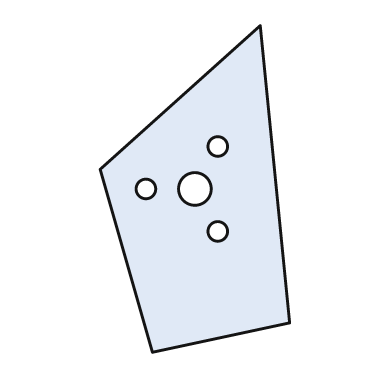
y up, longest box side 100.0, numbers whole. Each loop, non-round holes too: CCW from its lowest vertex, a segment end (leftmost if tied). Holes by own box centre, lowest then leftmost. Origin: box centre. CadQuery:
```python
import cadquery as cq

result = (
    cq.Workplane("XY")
    .moveTo(-13.0, -50.0)
    .lineTo(29.0, -41.0)
    .lineTo(20.0, 50.0)
    .lineTo(-29.0, 6.0)
    .close()
    .moveTo(7.0, -13.0)
    .circle(3.0)
    .moveTo(-15.0, 0.0)
    .circle(3.0)
    .moveTo(0.0, 0.0)
    .circle(5.0)
    .moveTo(7.0, 13.0)
    .circle(3.0)
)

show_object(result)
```